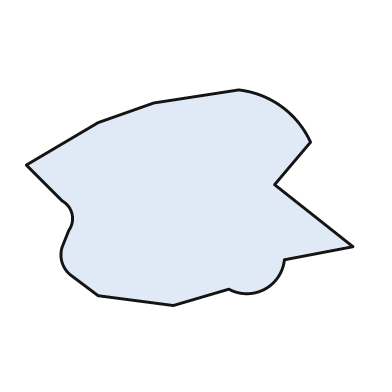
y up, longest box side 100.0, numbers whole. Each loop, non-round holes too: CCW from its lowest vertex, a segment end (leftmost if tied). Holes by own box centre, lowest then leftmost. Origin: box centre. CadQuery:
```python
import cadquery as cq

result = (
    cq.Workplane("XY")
    .moveTo(-5.0, -33.0)
    .lineTo(12.0, -28.0)
    .threePointArc((23.0, -28.0), (29.0, -19.0))
    .lineTo(50.0, -15.0)
    .lineTo(26.0, 4.0)
    .lineTo(37.0, 17.0)
    .threePointArc((28.0, 28.0), (15.0, 33.0))
    .lineTo(-11.0, 29.0)
    .lineTo(-28.0, 23.0)
    .lineTo(-50.0, 10.0)
    .lineTo(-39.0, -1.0)
    .threePointArc((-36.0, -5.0), (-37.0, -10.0))
    .lineTo(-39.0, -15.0)
    .threePointArc((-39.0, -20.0), (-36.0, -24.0))
    .lineTo(-28.0, -30.0)
    .close()
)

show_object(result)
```